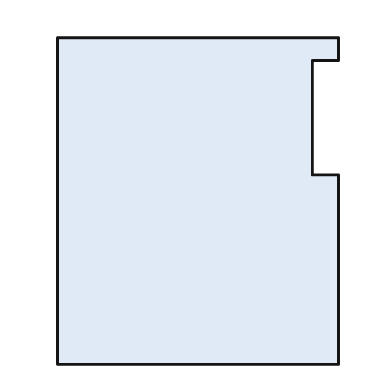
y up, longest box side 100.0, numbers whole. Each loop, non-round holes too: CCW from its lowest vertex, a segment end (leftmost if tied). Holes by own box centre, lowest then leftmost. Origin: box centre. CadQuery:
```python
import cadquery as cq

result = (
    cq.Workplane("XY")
    .moveTo(-43.0, -50.0)
    .lineTo(43.0, -50.0)
    .lineTo(43.0, 8.0)
    .lineTo(35.0, 8.0)
    .lineTo(35.0, 43.0)
    .lineTo(43.0, 43.0)
    .lineTo(43.0, 50.0)
    .lineTo(-43.0, 50.0)
    .close()
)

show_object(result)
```